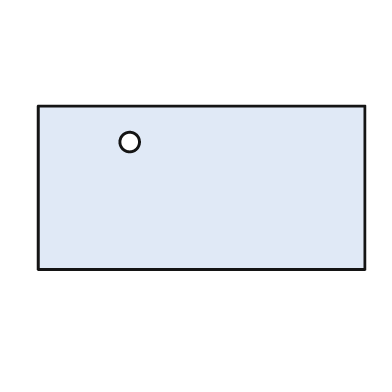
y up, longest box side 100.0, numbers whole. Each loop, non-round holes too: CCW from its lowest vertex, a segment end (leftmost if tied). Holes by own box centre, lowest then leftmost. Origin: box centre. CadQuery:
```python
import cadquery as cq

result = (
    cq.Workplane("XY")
    .moveTo(-50.0, -25.0)
    .lineTo(50.0, -25.0)
    .lineTo(50.0, 25.0)
    .lineTo(-50.0, 25.0)
    .close()
    .moveTo(-22.0, 14.0)
    .circle(3.0)
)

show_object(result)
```